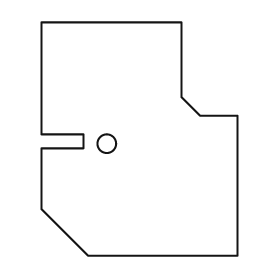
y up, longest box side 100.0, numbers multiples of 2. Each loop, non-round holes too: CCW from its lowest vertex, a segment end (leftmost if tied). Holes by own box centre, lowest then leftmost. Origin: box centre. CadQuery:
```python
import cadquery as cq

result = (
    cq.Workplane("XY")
    .moveTo(-22.0, -50.0)
    .lineTo(42.0, -50.0)
    .lineTo(42.0, 10.0)
    .lineTo(26.0, 10.0)
    .lineTo(18.0, 18.0)
    .lineTo(18.0, 50.0)
    .lineTo(-42.0, 50.0)
    .lineTo(-42.0, 2.0)
    .lineTo(-24.0, 2.0)
    .lineTo(-24.0, -4.0)
    .lineTo(-42.0, -4.0)
    .lineTo(-42.0, -30.0)
    .close()
    .moveTo(-14.0, -2.0)
    .circle(4.0)
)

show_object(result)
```